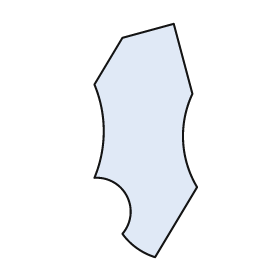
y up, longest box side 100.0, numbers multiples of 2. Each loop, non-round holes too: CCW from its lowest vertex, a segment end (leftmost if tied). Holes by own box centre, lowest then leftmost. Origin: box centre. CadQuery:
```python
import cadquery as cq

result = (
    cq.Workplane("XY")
    .moveTo(4.0, -50.0)
    .lineTo(22.0, -20.0)
    .threePointArc((16.0, 0.0), (20.0, 20.0))
    .lineTo(12.0, 50.0)
    .lineTo(-10.0, 44.0)
    .lineTo(-22.0, 24.0)
    .threePointArc((-18.0, 4.0), (-22.0, -16.0))
    .threePointArc((-8.0, -24.0), (-10.0, -40.0))
    .threePointArc((-4.0, -46.0), (4.0, -50.0))
    .close()
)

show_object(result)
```